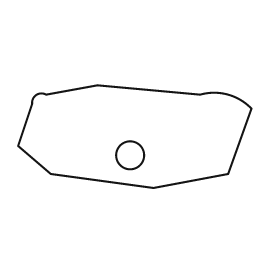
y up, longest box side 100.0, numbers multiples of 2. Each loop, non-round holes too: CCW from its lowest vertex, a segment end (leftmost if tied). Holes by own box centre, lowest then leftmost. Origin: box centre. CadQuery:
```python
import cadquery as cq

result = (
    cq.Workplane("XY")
    .moveTo(8.0, -22.0)
    .lineTo(40.0, -16.0)
    .lineTo(50.0, 12.0)
    .threePointArc((40.0, 18.0), (28.0, 18.0))
    .lineTo(-16.0, 22.0)
    .lineTo(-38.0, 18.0)
    .threePointArc((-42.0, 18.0), (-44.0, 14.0))
    .lineTo(-50.0, -4.0)
    .lineTo(-36.0, -16.0)
    .close()
    .moveTo(-2.0, -8.0)
    .circle(6.0)
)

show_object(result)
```